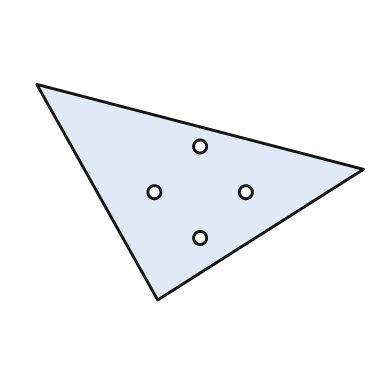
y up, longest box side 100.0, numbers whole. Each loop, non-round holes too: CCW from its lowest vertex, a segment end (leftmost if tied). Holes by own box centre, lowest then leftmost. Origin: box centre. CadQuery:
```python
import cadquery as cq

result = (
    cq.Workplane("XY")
    .moveTo(-13.0, -33.0)
    .lineTo(50.0, 7.0)
    .lineTo(-50.0, 33.0)
    .close()
    .moveTo(0.0, -14.0)
    .circle(2.0)
    .moveTo(-14.0, 0.0)
    .circle(2.0)
    .moveTo(14.0, 0.0)
    .circle(2.0)
    .moveTo(0.0, 14.0)
    .circle(2.0)
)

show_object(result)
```